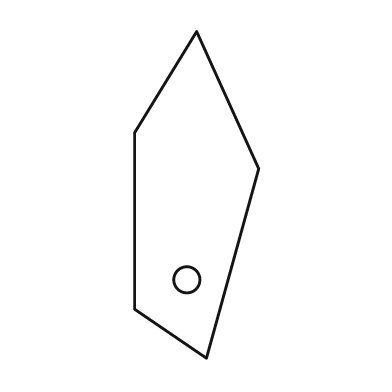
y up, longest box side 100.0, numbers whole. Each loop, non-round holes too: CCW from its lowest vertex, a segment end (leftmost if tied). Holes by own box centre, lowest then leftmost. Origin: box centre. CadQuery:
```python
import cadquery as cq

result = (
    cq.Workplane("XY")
    .moveTo(3.0, -50.0)
    .lineTo(19.0, 8.0)
    .lineTo(0.0, 50.0)
    .lineTo(-19.0, 19.0)
    .lineTo(-19.0, -35.0)
    .close()
    .moveTo(-3.0, -26.0)
    .circle(4.0)
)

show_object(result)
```